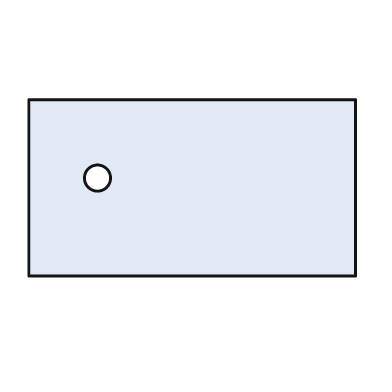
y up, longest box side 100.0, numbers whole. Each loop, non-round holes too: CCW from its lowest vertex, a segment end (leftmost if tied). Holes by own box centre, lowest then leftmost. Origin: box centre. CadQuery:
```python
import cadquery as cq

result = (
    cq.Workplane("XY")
    .moveTo(-50.0, -27.0)
    .lineTo(50.0, -27.0)
    .lineTo(50.0, 27.0)
    .lineTo(-50.0, 27.0)
    .close()
    .moveTo(-29.0, 3.0)
    .circle(4.0)
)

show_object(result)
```